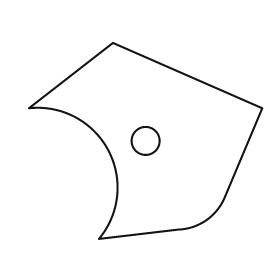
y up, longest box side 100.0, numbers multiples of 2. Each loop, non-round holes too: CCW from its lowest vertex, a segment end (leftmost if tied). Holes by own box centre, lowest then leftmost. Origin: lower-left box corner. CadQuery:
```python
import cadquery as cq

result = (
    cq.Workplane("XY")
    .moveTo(30.0, 0.0)
    .lineTo(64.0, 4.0)
    .threePointArc((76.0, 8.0), (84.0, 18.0))
    .lineTo(100.0, 56.0)
    .lineTo(36.0, 84.0)
    .lineTo(0.0, 56.0)
    .threePointArc((34.0, 38.0), (30.0, 0.0))
    .close()
    .moveTo(50.0, 42.0)
    .circle(6.0)
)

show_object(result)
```